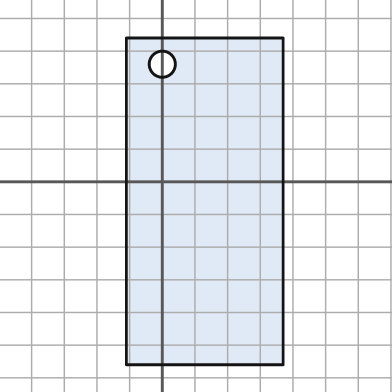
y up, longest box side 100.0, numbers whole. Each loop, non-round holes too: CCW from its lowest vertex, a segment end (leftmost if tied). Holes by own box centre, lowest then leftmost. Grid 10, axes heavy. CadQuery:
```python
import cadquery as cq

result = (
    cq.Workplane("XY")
    .moveTo(-11.0, -56.0)
    .lineTo(37.0, -56.0)
    .lineTo(37.0, 44.0)
    .lineTo(-11.0, 44.0)
    .close()
    .moveTo(0.0, 36.0)
    .circle(4.0)
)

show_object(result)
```